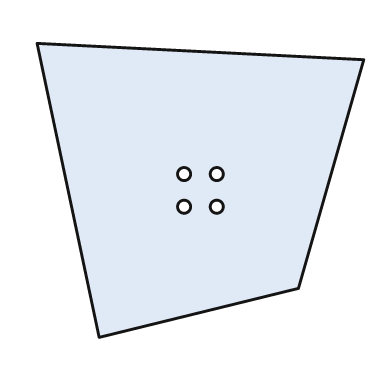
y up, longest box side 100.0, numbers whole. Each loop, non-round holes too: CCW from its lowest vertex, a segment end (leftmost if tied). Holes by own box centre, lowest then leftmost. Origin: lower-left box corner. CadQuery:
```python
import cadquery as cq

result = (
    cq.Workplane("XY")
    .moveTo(19.0, 0.0)
    .lineTo(80.0, 15.0)
    .lineTo(100.0, 85.0)
    .lineTo(0.0, 90.0)
    .close()
    .moveTo(45.0, 40.0)
    .circle(2.0)
    .moveTo(55.0, 40.0)
    .circle(2.0)
    .moveTo(45.0, 50.0)
    .circle(2.0)
    .moveTo(55.0, 50.0)
    .circle(2.0)
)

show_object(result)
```